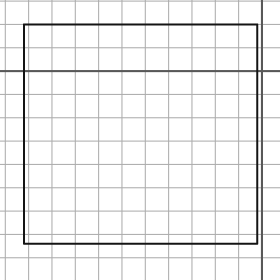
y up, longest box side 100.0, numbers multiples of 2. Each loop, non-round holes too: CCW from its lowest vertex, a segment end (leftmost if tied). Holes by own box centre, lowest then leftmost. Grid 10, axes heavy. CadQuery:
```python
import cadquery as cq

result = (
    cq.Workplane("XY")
    .moveTo(-102.0, -74.0)
    .lineTo(-2.0, -74.0)
    .lineTo(-2.0, 20.0)
    .lineTo(-102.0, 20.0)
    .close()
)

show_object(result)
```